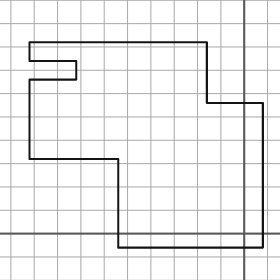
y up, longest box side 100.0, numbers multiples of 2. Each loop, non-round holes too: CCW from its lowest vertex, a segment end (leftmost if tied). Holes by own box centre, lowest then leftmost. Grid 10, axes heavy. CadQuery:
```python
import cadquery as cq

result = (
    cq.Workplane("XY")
    .moveTo(-54.0, -6.0)
    .lineTo(8.0, -6.0)
    .lineTo(8.0, 56.0)
    .lineTo(-16.0, 56.0)
    .lineTo(-16.0, 82.0)
    .lineTo(-92.0, 82.0)
    .lineTo(-92.0, 74.0)
    .lineTo(-72.0, 74.0)
    .lineTo(-72.0, 66.0)
    .lineTo(-92.0, 66.0)
    .lineTo(-92.0, 32.0)
    .lineTo(-54.0, 32.0)
    .close()
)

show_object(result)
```